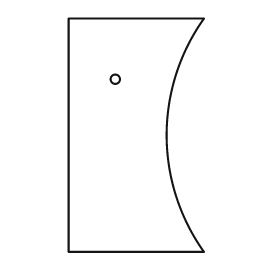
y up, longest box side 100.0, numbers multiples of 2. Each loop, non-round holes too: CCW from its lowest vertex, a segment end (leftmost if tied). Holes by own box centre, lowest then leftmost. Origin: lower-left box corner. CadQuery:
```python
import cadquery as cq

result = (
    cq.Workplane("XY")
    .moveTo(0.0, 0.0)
    .lineTo(58.0, 0.0)
    .threePointArc((42.0, 50.0), (58.0, 100.0))
    .lineTo(0.0, 100.0)
    .close()
    .moveTo(20.0, 74.0)
    .circle(2.0)
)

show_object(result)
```